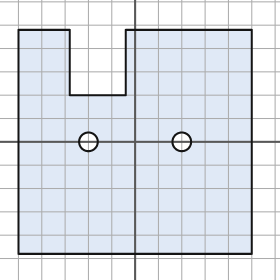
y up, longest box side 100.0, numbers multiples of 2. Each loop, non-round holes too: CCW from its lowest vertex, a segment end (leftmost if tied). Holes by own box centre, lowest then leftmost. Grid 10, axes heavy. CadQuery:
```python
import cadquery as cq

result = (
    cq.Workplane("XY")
    .moveTo(-50.0, -48.0)
    .lineTo(50.0, -48.0)
    .lineTo(50.0, 48.0)
    .lineTo(-4.0, 48.0)
    .lineTo(-4.0, 20.0)
    .lineTo(-28.0, 20.0)
    .lineTo(-28.0, 48.0)
    .lineTo(-50.0, 48.0)
    .close()
    .moveTo(-20.0, 0.0)
    .circle(4.0)
    .moveTo(20.0, 0.0)
    .circle(4.0)
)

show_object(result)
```